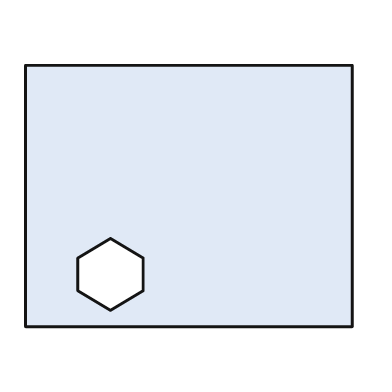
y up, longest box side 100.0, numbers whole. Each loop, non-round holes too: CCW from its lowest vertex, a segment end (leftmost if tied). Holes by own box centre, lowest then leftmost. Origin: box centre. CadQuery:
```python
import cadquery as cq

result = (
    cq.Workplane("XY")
    .moveTo(-50.0, -40.0)
    .lineTo(50.0, -40.0)
    .lineTo(50.0, 40.0)
    .lineTo(-50.0, 40.0)
    .close()
    .moveTo(-24.0, -35.0)
    .lineTo(-14.0, -29.0)
    .lineTo(-14.0, -19.0)
    .lineTo(-24.0, -13.0)
    .lineTo(-34.0, -19.0)
    .lineTo(-34.0, -29.0)
    .close()
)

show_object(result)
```